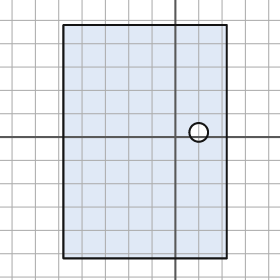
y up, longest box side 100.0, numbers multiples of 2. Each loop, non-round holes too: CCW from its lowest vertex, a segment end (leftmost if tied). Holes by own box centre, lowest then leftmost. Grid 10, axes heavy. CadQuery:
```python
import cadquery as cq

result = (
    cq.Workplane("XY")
    .moveTo(-48.0, -52.0)
    .lineTo(22.0, -52.0)
    .lineTo(22.0, 48.0)
    .lineTo(-48.0, 48.0)
    .close()
    .moveTo(10.0, 2.0)
    .circle(4.0)
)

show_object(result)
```